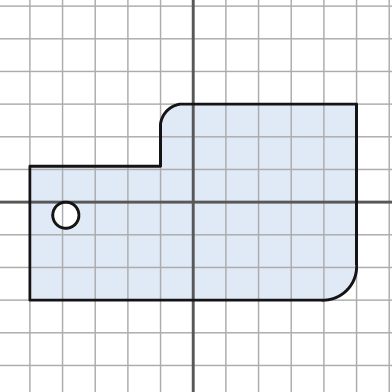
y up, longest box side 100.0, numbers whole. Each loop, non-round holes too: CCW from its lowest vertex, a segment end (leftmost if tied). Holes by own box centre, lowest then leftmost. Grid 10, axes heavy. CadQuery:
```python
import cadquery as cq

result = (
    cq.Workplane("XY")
    .moveTo(-50.0, -30.0)
    .lineTo(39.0, -30.0)
    .threePointArc((47.0, -27.0), (50.0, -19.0))
    .lineTo(50.0, 30.0)
    .lineTo(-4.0, 30.0)
    .threePointArc((-8.0, 28.0), (-10.0, 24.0))
    .lineTo(-10.0, 11.0)
    .lineTo(-50.0, 11.0)
    .close()
    .moveTo(-39.0, -4.0)
    .circle(4.0)
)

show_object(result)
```